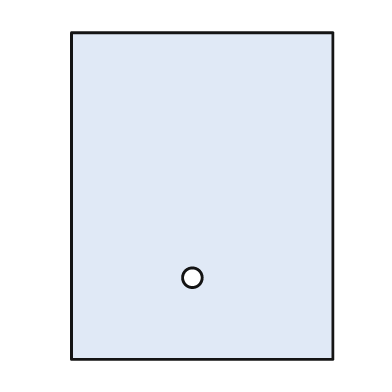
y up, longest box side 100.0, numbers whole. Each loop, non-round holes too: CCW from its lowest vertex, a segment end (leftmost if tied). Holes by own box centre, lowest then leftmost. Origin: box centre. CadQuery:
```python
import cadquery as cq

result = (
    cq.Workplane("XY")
    .moveTo(-40.0, -50.0)
    .lineTo(40.0, -50.0)
    .lineTo(40.0, 50.0)
    .lineTo(-40.0, 50.0)
    .close()
    .moveTo(-3.0, -25.0)
    .circle(3.0)
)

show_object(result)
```